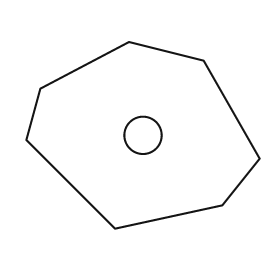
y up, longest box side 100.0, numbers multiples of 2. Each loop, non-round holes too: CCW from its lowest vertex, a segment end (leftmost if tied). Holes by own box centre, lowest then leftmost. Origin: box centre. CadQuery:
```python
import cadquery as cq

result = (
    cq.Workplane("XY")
    .moveTo(-12.0, -40.0)
    .lineTo(34.0, -30.0)
    .lineTo(50.0, -10.0)
    .lineTo(26.0, 32.0)
    .lineTo(-6.0, 40.0)
    .lineTo(-44.0, 20.0)
    .lineTo(-50.0, -2.0)
    .close()
    .moveTo(0.0, 0.0)
    .circle(8.0)
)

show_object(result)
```